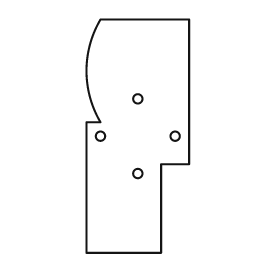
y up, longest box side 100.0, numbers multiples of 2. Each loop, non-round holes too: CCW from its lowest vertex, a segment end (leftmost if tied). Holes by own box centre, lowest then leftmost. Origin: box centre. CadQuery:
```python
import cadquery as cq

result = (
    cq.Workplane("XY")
    .moveTo(-22.0, -50.0)
    .lineTo(10.0, -50.0)
    .lineTo(10.0, -12.0)
    .lineTo(22.0, -12.0)
    .lineTo(22.0, 50.0)
    .lineTo(-16.0, 50.0)
    .threePointArc((-22.0, 28.0), (-16.0, 6.0))
    .lineTo(-22.0, 6.0)
    .close()
    .moveTo(0.0, -16.0)
    .circle(2.0)
    .moveTo(-16.0, 0.0)
    .circle(2.0)
    .moveTo(16.0, 0.0)
    .circle(2.0)
    .moveTo(0.0, 16.0)
    .circle(2.0)
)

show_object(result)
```